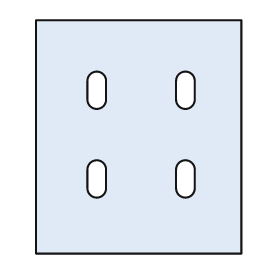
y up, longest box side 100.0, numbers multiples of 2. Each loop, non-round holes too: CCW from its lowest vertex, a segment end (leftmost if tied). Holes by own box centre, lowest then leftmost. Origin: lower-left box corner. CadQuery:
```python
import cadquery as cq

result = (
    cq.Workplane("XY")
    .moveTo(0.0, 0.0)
    .lineTo(88.0, 0.0)
    .lineTo(88.0, 100.0)
    .lineTo(0.0, 100.0)
    .close()
    .moveTo(22.0, 28.0)
    .threePointArc((26.0, 24.0), (30.0, 28.0))
    .lineTo(30.0, 36.0)
    .threePointArc((26.0, 40.0), (22.0, 36.0))
    .close()
    .moveTo(60.0, 28.0)
    .threePointArc((64.0, 24.0), (68.0, 28.0))
    .lineTo(68.0, 36.0)
    .threePointArc((64.0, 40.0), (60.0, 36.0))
    .close()
    .moveTo(22.0, 66.0)
    .threePointArc((26.0, 62.0), (30.0, 66.0))
    .lineTo(30.0, 74.0)
    .threePointArc((26.0, 78.0), (22.0, 74.0))
    .close()
    .moveTo(60.0, 66.0)
    .threePointArc((64.0, 62.0), (68.0, 66.0))
    .lineTo(68.0, 74.0)
    .threePointArc((64.0, 78.0), (60.0, 74.0))
    .close()
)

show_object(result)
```